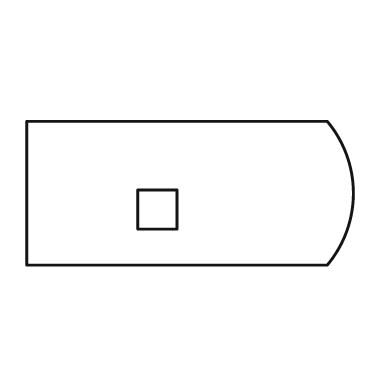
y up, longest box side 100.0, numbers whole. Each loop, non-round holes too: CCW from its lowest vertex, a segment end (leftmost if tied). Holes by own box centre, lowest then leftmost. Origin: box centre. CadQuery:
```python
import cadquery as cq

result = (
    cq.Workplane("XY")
    .moveTo(-50.0, -22.0)
    .lineTo(42.0, -22.0)
    .threePointArc((50.0, 0.0), (42.0, 22.0))
    .lineTo(-50.0, 22.0)
    .close()
    .moveTo(-16.0, -11.0)
    .lineTo(-4.0, -11.0)
    .lineTo(-4.0, 1.0)
    .lineTo(-16.0, 1.0)
    .close()
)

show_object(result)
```